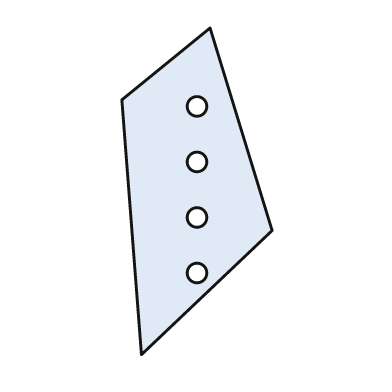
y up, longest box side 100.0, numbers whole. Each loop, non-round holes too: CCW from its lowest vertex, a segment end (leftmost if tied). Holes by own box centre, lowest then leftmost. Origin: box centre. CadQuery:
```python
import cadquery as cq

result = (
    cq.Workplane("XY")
    .moveTo(-17.0, -50.0)
    .lineTo(23.0, -12.0)
    .lineTo(4.0, 50.0)
    .lineTo(-23.0, 28.0)
    .close()
    .moveTo(0.0, -25.0)
    .circle(3.0)
    .moveTo(0.0, -8.0)
    .circle(3.0)
    .moveTo(0.0, 9.0)
    .circle(3.0)
    .moveTo(0.0, 26.0)
    .circle(3.0)
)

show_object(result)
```